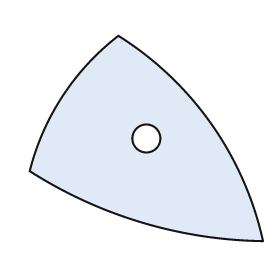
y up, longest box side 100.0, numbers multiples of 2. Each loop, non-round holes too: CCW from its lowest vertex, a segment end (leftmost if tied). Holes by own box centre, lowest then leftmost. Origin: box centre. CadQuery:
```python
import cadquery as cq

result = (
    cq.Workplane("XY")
    .moveTo(50.0, -44.0)
    .threePointArc((28.0, 6.0), (-12.0, 44.0))
    .threePointArc((-36.0, 18.0), (-50.0, -14.0))
    .threePointArc((-2.0, -36.0), (50.0, -44.0))
    .close()
    .moveTo(0.0, 0.0)
    .circle(6.0)
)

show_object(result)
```